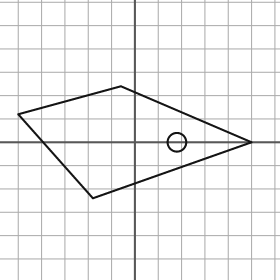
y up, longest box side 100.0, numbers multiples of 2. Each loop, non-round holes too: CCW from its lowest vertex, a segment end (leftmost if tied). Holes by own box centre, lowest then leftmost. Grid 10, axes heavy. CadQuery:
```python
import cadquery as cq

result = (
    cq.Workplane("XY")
    .moveTo(-18.0, -24.0)
    .lineTo(50.0, 0.0)
    .lineTo(-6.0, 24.0)
    .lineTo(-50.0, 12.0)
    .close()
    .moveTo(18.0, 0.0)
    .circle(4.0)
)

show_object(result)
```